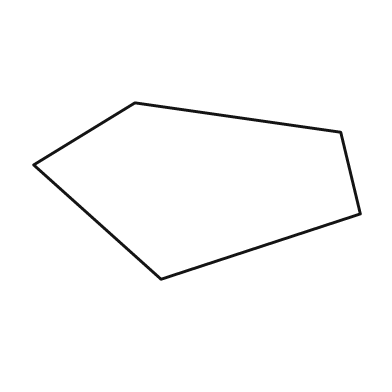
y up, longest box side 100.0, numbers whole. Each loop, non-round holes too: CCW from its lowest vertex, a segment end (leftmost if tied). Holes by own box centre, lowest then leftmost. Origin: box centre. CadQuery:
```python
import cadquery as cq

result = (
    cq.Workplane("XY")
    .moveTo(-11.0, -27.0)
    .lineTo(50.0, -7.0)
    .lineTo(44.0, 18.0)
    .lineTo(-19.0, 27.0)
    .lineTo(-50.0, 8.0)
    .close()
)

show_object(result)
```